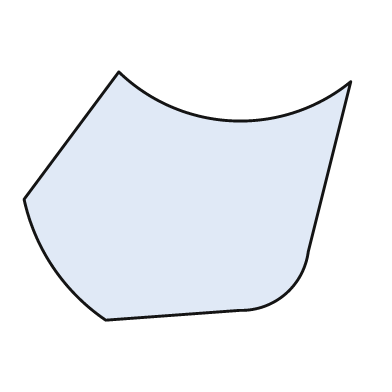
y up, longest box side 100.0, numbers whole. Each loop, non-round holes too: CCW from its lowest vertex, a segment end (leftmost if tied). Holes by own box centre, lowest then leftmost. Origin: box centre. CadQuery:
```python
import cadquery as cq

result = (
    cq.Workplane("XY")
    .moveTo(-25.0, -38.0)
    .lineTo(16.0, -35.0)
    .threePointArc((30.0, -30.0), (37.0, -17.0))
    .lineTo(50.0, 35.0)
    .threePointArc((14.0, 23.0), (-21.0, 38.0))
    .lineTo(-50.0, -1.0)
    .threePointArc((-41.0, -22.0), (-25.0, -38.0))
    .close()
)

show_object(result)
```